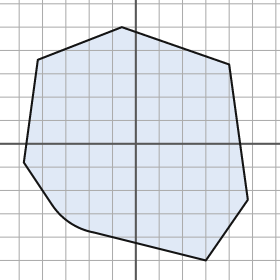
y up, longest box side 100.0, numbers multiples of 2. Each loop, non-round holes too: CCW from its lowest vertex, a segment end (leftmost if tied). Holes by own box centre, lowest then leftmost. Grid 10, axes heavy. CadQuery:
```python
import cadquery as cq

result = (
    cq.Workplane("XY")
    .moveTo(30.0, -50.0)
    .lineTo(48.0, -24.0)
    .lineTo(40.0, 34.0)
    .lineTo(-6.0, 50.0)
    .lineTo(-42.0, 36.0)
    .lineTo(-48.0, -8.0)
    .lineTo(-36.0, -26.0)
    .threePointArc((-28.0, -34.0), (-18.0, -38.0))
    .close()
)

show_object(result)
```